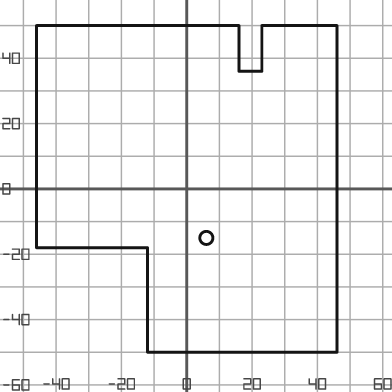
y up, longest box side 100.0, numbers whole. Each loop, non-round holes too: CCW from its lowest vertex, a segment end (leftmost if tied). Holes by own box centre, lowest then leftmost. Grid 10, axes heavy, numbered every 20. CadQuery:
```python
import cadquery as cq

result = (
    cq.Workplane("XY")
    .moveTo(-12.0, -50.0)
    .lineTo(46.0, -50.0)
    .lineTo(46.0, 50.0)
    .lineTo(23.0, 50.0)
    .lineTo(23.0, 36.0)
    .lineTo(16.0, 36.0)
    .lineTo(16.0, 50.0)
    .lineTo(-46.0, 50.0)
    .lineTo(-46.0, -18.0)
    .lineTo(-12.0, -18.0)
    .close()
    .moveTo(6.0, -15.0)
    .circle(2.0)
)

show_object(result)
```